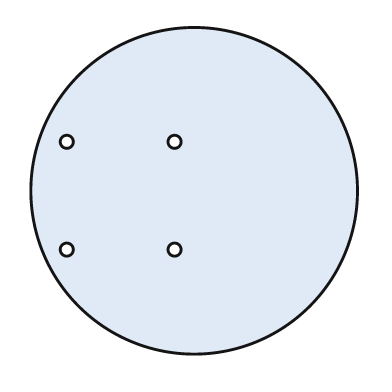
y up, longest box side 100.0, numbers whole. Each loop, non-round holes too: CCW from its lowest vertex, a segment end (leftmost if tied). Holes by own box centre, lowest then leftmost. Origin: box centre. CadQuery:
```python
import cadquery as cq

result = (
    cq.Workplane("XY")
    .moveTo(0.0, 0.0)
    .circle(50.0)
    .moveTo(-39.0, -18.0)
    .circle(2.0)
    .moveTo(-6.0, -18.0)
    .circle(2.0)
    .moveTo(-39.0, 15.0)
    .circle(2.0)
    .moveTo(-6.0, 15.0)
    .circle(2.0)
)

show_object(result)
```